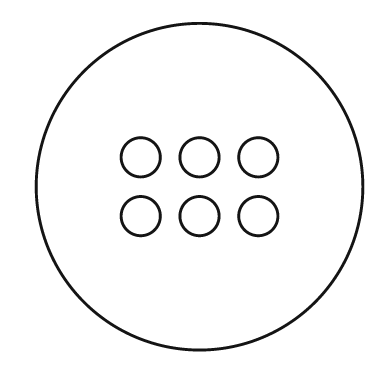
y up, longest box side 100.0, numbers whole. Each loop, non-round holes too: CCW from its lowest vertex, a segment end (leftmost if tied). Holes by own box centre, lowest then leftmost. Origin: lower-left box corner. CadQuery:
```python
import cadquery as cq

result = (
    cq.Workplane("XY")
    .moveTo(50.0, 50.0)
    .circle(50.0)
    .moveTo(32.0, 41.0)
    .circle(6.0)
    .moveTo(50.0, 41.0)
    .circle(6.0)
    .moveTo(68.0, 41.0)
    .circle(6.0)
    .moveTo(32.0, 59.0)
    .circle(6.0)
    .moveTo(50.0, 59.0)
    .circle(6.0)
    .moveTo(68.0, 59.0)
    .circle(6.0)
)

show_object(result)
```